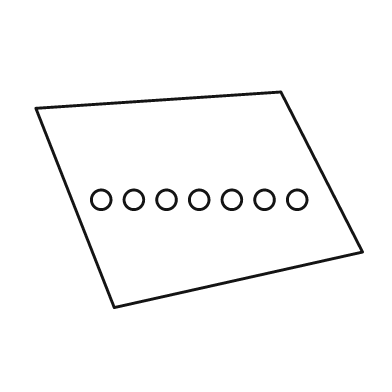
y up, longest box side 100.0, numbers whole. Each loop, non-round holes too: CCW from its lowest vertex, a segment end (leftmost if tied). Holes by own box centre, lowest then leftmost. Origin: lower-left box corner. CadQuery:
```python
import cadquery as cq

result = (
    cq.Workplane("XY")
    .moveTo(24.0, 0.0)
    .lineTo(100.0, 17.0)
    .lineTo(75.0, 66.0)
    .lineTo(0.0, 61.0)
    .close()
    .moveTo(20.0, 33.0)
    .circle(3.0)
    .moveTo(30.0, 33.0)
    .circle(3.0)
    .moveTo(40.0, 33.0)
    .circle(3.0)
    .moveTo(50.0, 33.0)
    .circle(3.0)
    .moveTo(60.0, 33.0)
    .circle(3.0)
    .moveTo(70.0, 33.0)
    .circle(3.0)
    .moveTo(80.0, 33.0)
    .circle(3.0)
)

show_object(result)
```